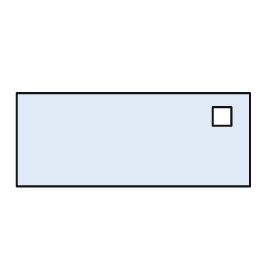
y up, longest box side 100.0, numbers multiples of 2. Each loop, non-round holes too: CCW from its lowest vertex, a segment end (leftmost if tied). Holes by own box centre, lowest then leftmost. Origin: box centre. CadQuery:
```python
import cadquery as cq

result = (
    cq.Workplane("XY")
    .moveTo(-50.0, -20.0)
    .lineTo(50.0, -20.0)
    .lineTo(50.0, 20.0)
    .lineTo(-50.0, 20.0)
    .close()
    .moveTo(34.0, 6.0)
    .lineTo(42.0, 6.0)
    .lineTo(42.0, 14.0)
    .lineTo(34.0, 14.0)
    .close()
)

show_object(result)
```